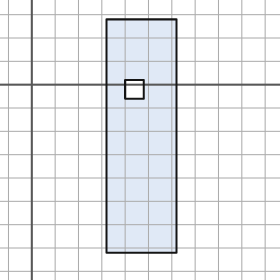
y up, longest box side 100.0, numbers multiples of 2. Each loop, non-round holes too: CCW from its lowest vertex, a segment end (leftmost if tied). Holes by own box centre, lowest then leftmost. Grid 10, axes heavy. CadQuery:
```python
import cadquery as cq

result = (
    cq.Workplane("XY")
    .moveTo(32.0, -72.0)
    .lineTo(62.0, -72.0)
    .lineTo(62.0, 28.0)
    .lineTo(32.0, 28.0)
    .close()
    .moveTo(40.0, -6.0)
    .lineTo(48.0, -6.0)
    .lineTo(48.0, 2.0)
    .lineTo(40.0, 2.0)
    .close()
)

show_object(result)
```